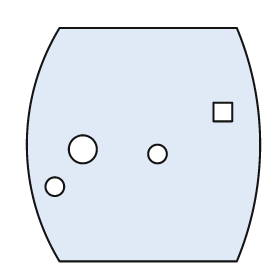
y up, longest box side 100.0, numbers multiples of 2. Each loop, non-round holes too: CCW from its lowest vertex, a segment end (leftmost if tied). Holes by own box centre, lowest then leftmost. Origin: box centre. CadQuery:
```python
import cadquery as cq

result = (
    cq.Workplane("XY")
    .moveTo(-36.0, -50.0)
    .lineTo(40.0, -50.0)
    .threePointArc((50.0, 0.0), (40.0, 50.0))
    .lineTo(-36.0, 50.0)
    .threePointArc((-50.0, 0.0), (-36.0, -50.0))
    .close()
    .moveTo(-38.0, -18.0)
    .circle(4.0)
    .moveTo(6.0, -4.0)
    .circle(4.0)
    .moveTo(-26.0, -2.0)
    .circle(6.0)
    .moveTo(30.0, 10.0)
    .lineTo(38.0, 10.0)
    .lineTo(38.0, 18.0)
    .lineTo(30.0, 18.0)
    .close()
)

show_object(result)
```